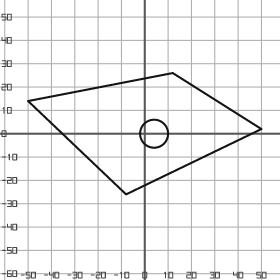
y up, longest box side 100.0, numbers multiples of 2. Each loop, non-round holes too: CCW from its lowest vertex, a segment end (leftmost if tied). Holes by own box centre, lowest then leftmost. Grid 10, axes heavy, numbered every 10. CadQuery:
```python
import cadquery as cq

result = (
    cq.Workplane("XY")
    .moveTo(-8.0, -26.0)
    .lineTo(50.0, 2.0)
    .lineTo(12.0, 26.0)
    .lineTo(-50.0, 14.0)
    .close()
    .moveTo(4.0, 0.0)
    .circle(6.0)
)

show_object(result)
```